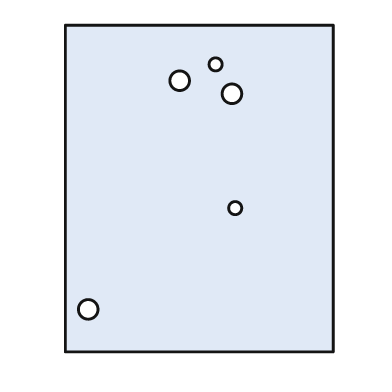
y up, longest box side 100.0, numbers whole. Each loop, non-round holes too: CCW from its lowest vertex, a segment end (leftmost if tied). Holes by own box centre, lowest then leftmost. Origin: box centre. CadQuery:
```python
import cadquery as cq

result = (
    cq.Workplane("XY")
    .moveTo(-41.0, -50.0)
    .lineTo(41.0, -50.0)
    .lineTo(41.0, 50.0)
    .lineTo(-41.0, 50.0)
    .close()
    .moveTo(-34.0, -37.0)
    .circle(3.0)
    .moveTo(11.0, -6.0)
    .circle(2.0)
    .moveTo(10.0, 29.0)
    .circle(3.0)
    .moveTo(-6.0, 33.0)
    .circle(3.0)
    .moveTo(5.0, 38.0)
    .circle(2.0)
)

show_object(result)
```